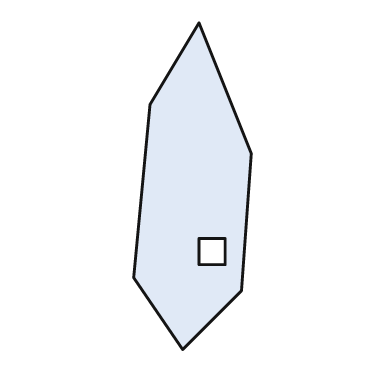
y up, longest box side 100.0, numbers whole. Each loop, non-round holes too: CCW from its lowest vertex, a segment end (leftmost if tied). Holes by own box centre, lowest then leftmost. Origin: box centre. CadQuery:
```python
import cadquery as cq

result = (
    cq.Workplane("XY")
    .moveTo(-3.0, -50.0)
    .lineTo(15.0, -32.0)
    .lineTo(18.0, 10.0)
    .lineTo(2.0, 50.0)
    .lineTo(-13.0, 25.0)
    .lineTo(-18.0, -28.0)
    .close()
    .moveTo(2.0, -24.0)
    .lineTo(10.0, -24.0)
    .lineTo(10.0, -16.0)
    .lineTo(2.0, -16.0)
    .close()
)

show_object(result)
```